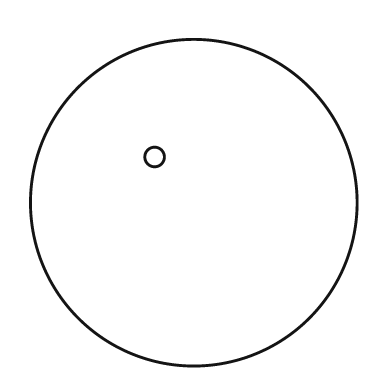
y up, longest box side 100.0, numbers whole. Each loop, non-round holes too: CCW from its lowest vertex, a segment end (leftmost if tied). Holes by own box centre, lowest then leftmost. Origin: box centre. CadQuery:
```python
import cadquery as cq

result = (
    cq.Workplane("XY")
    .moveTo(0.0, 0.0)
    .circle(50.0)
    .moveTo(-12.0, 14.0)
    .circle(3.0)
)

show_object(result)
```